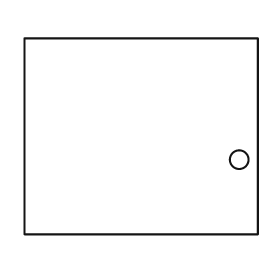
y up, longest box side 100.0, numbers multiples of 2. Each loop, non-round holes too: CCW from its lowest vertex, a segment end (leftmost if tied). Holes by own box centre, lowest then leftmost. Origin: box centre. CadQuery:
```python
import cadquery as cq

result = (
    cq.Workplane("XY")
    .moveTo(-50.0, -42.0)
    .lineTo(50.0, -42.0)
    .lineTo(50.0, 42.0)
    .lineTo(-50.0, 42.0)
    .close()
    .moveTo(42.0, -10.0)
    .circle(4.0)
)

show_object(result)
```